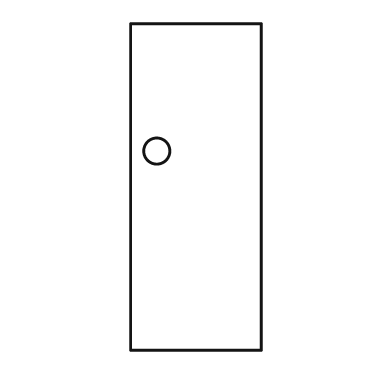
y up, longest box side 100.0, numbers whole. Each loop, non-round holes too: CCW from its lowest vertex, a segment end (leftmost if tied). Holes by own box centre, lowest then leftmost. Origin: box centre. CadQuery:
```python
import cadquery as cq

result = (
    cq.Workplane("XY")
    .moveTo(-20.0, -50.0)
    .lineTo(20.0, -50.0)
    .lineTo(20.0, 50.0)
    .lineTo(-20.0, 50.0)
    .close()
    .moveTo(-12.0, 11.0)
    .circle(4.0)
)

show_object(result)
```